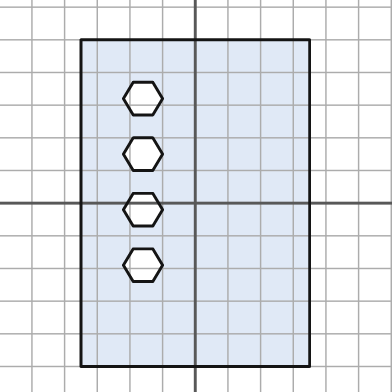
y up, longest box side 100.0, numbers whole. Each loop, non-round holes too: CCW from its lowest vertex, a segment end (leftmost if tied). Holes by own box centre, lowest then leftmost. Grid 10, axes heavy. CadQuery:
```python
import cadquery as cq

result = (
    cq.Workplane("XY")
    .moveTo(-35.0, -50.0)
    .lineTo(35.0, -50.0)
    .lineTo(35.0, 50.0)
    .lineTo(-35.0, 50.0)
    .close()
    .moveTo(-19.0, -24.0)
    .lineTo(-13.0, -24.0)
    .lineTo(-10.0, -19.0)
    .lineTo(-13.0, -14.0)
    .lineTo(-19.0, -14.0)
    .lineTo(-22.0, -19.0)
    .close()
    .moveTo(-19.0, -7.0)
    .lineTo(-13.0, -7.0)
    .lineTo(-10.0, -2.0)
    .lineTo(-13.0, 3.0)
    .lineTo(-19.0, 3.0)
    .lineTo(-22.0, -2.0)
    .close()
    .moveTo(-19.0, 10.0)
    .lineTo(-13.0, 10.0)
    .lineTo(-10.0, 15.0)
    .lineTo(-13.0, 20.0)
    .lineTo(-19.0, 20.0)
    .lineTo(-22.0, 15.0)
    .close()
    .moveTo(-19.0, 27.0)
    .lineTo(-13.0, 27.0)
    .lineTo(-10.0, 32.0)
    .lineTo(-13.0, 37.0)
    .lineTo(-19.0, 37.0)
    .lineTo(-22.0, 32.0)
    .close()
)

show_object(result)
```